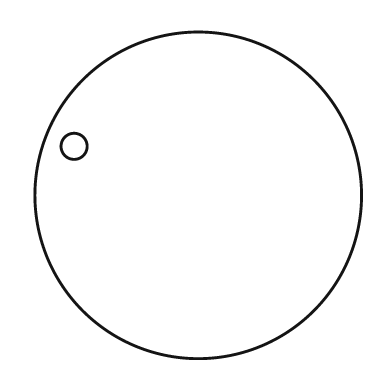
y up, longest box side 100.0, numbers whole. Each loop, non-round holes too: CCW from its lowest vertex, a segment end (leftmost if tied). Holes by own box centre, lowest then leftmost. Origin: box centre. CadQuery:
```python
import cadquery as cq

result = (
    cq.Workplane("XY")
    .moveTo(0.0, 0.0)
    .circle(50.0)
    .moveTo(-38.0, 15.0)
    .circle(4.0)
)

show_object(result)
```